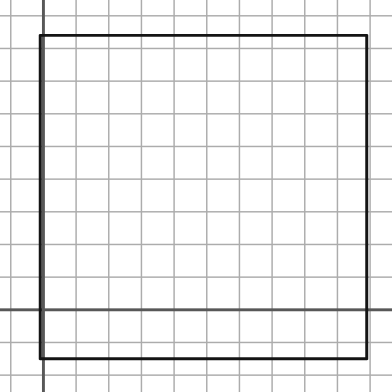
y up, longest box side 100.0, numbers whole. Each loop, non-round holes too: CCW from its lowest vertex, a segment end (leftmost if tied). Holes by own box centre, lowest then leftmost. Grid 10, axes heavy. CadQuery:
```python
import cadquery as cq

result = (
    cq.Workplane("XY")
    .moveTo(-1.0, -15.0)
    .lineTo(99.0, -15.0)
    .lineTo(99.0, 84.0)
    .lineTo(-1.0, 84.0)
    .close()
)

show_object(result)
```